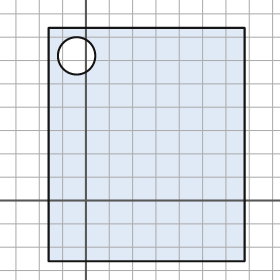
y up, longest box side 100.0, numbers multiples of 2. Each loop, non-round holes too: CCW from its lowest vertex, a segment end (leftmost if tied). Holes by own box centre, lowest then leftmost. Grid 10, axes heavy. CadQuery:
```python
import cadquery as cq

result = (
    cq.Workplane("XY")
    .moveTo(-16.0, -26.0)
    .lineTo(68.0, -26.0)
    .lineTo(68.0, 74.0)
    .lineTo(-16.0, 74.0)
    .close()
    .moveTo(-4.0, 62.0)
    .circle(8.0)
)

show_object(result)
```